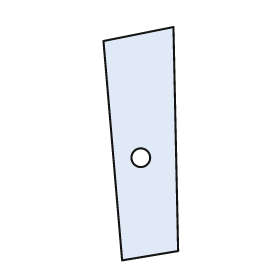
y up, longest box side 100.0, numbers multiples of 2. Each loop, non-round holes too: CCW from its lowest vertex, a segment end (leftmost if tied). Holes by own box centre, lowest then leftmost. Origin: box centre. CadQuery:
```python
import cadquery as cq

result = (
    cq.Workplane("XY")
    .moveTo(-8.0, -50.0)
    .lineTo(16.0, -46.0)
    .lineTo(14.0, 50.0)
    .lineTo(-16.0, 44.0)
    .close()
    .moveTo(0.0, -6.0)
    .circle(4.0)
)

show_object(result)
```